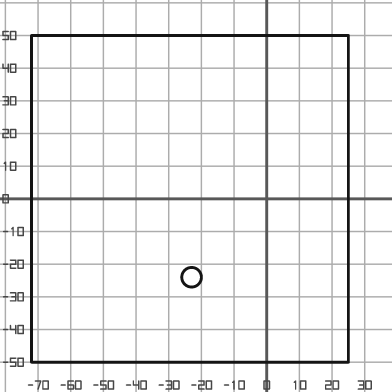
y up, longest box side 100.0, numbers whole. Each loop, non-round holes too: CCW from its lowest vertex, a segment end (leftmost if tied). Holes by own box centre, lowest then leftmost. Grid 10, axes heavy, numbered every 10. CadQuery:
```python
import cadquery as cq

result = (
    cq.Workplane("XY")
    .moveTo(-72.0, -50.0)
    .lineTo(25.0, -50.0)
    .lineTo(25.0, 50.0)
    .lineTo(-72.0, 50.0)
    .close()
    .moveTo(-23.0, -24.0)
    .circle(3.0)
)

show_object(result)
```